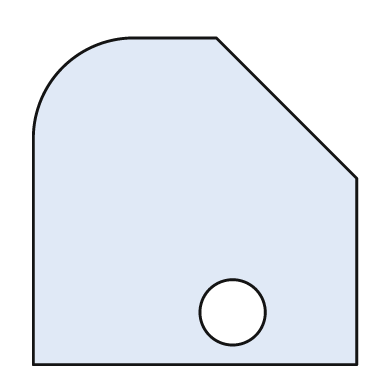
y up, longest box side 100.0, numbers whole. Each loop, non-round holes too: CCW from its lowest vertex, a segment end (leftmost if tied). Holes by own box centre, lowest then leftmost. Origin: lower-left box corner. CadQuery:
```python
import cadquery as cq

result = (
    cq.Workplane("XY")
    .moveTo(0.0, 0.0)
    .lineTo(99.0, 0.0)
    .lineTo(99.0, 57.0)
    .lineTo(56.0, 100.0)
    .lineTo(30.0, 100.0)
    .threePointArc((9.0, 91.0), (0.0, 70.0))
    .close()
    .moveTo(61.0, 16.0)
    .circle(10.0)
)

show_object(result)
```